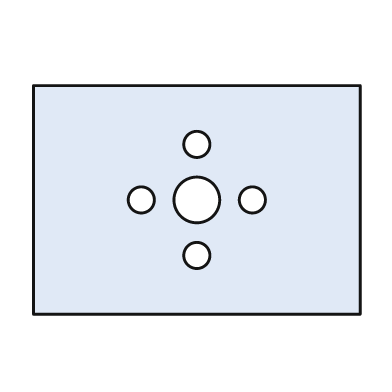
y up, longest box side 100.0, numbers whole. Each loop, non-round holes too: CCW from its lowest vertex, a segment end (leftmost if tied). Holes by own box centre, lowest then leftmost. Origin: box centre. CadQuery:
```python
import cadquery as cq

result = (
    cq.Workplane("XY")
    .moveTo(-50.0, -35.0)
    .lineTo(50.0, -35.0)
    .lineTo(50.0, 35.0)
    .lineTo(-50.0, 35.0)
    .close()
    .moveTo(0.0, -17.0)
    .circle(4.0)
    .moveTo(-17.0, 0.0)
    .circle(4.0)
    .moveTo(0.0, 0.0)
    .circle(7.0)
    .moveTo(17.0, 0.0)
    .circle(4.0)
    .moveTo(0.0, 17.0)
    .circle(4.0)
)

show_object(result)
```